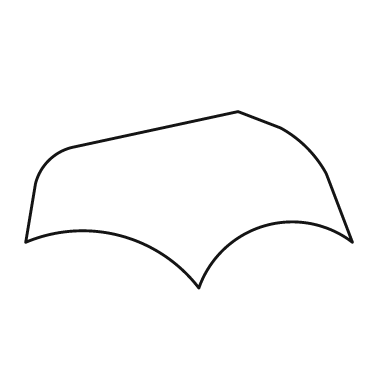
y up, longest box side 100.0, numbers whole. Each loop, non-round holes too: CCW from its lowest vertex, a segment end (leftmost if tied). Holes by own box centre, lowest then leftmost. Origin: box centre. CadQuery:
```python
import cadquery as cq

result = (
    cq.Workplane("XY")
    .moveTo(3.0, -27.0)
    .threePointArc((23.0, -8.0), (50.0, -13.0))
    .lineTo(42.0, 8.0)
    .threePointArc((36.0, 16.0), (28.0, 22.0))
    .lineTo(15.0, 27.0)
    .lineTo(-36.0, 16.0)
    .threePointArc((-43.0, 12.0), (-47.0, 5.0))
    .lineTo(-50.0, -13.0)
    .threePointArc((-21.0, -11.0), (3.0, -27.0))
    .close()
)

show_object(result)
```